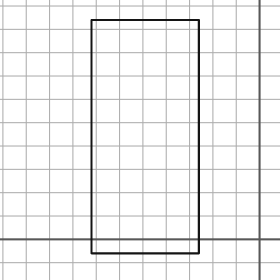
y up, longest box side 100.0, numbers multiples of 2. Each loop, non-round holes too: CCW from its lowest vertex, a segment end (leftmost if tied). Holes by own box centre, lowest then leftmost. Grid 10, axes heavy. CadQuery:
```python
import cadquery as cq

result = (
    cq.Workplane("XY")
    .moveTo(-72.0, -6.0)
    .lineTo(-26.0, -6.0)
    .lineTo(-26.0, 94.0)
    .lineTo(-72.0, 94.0)
    .close()
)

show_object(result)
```